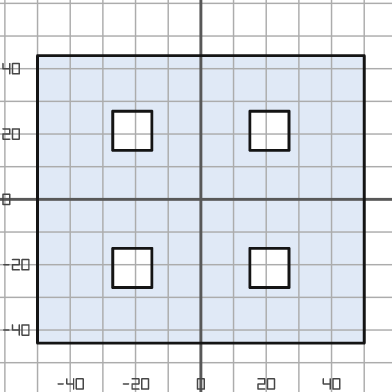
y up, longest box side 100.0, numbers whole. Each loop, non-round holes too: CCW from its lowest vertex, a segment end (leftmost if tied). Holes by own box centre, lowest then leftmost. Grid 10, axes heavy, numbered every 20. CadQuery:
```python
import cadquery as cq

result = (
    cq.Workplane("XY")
    .moveTo(-50.0, -44.0)
    .lineTo(50.0, -44.0)
    .lineTo(50.0, 44.0)
    .lineTo(-50.0, 44.0)
    .close()
    .moveTo(-27.0, -27.0)
    .lineTo(-15.0, -27.0)
    .lineTo(-15.0, -15.0)
    .lineTo(-27.0, -15.0)
    .close()
    .moveTo(15.0, -27.0)
    .lineTo(27.0, -27.0)
    .lineTo(27.0, -15.0)
    .lineTo(15.0, -15.0)
    .close()
    .moveTo(-27.0, 15.0)
    .lineTo(-15.0, 15.0)
    .lineTo(-15.0, 27.0)
    .lineTo(-27.0, 27.0)
    .close()
    .moveTo(15.0, 15.0)
    .lineTo(27.0, 15.0)
    .lineTo(27.0, 27.0)
    .lineTo(15.0, 27.0)
    .close()
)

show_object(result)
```